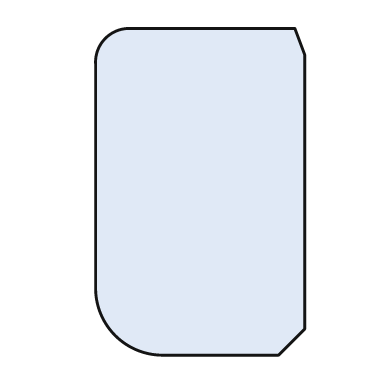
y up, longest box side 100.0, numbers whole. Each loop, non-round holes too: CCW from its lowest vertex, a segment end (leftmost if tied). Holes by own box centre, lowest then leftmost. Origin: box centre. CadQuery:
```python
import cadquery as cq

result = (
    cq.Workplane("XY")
    .moveTo(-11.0, -50.0)
    .lineTo(24.0, -50.0)
    .lineTo(32.0, -42.0)
    .lineTo(32.0, 42.0)
    .lineTo(29.0, 50.0)
    .lineTo(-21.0, 50.0)
    .threePointArc((-29.0, 47.0), (-32.0, 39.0))
    .lineTo(-32.0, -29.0)
    .threePointArc((-26.0, -44.0), (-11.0, -50.0))
    .close()
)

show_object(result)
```